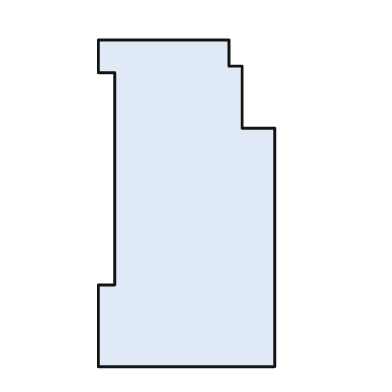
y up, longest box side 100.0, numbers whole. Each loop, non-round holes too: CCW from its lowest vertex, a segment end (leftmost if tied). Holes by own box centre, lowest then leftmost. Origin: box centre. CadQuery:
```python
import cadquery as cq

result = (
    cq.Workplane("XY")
    .moveTo(-27.0, -50.0)
    .lineTo(27.0, -50.0)
    .lineTo(27.0, 23.0)
    .lineTo(17.0, 23.0)
    .lineTo(17.0, 42.0)
    .lineTo(13.0, 42.0)
    .lineTo(13.0, 50.0)
    .lineTo(-27.0, 50.0)
    .lineTo(-27.0, 40.0)
    .lineTo(-22.0, 40.0)
    .lineTo(-22.0, -25.0)
    .lineTo(-27.0, -25.0)
    .close()
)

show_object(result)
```